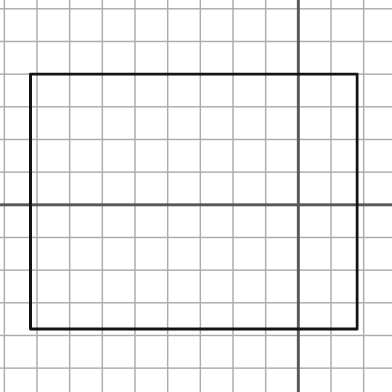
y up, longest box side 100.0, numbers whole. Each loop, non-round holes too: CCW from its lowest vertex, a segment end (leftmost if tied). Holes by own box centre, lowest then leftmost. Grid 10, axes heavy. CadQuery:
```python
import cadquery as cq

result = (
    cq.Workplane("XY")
    .moveTo(-82.0, -38.0)
    .lineTo(18.0, -38.0)
    .lineTo(18.0, 40.0)
    .lineTo(-82.0, 40.0)
    .close()
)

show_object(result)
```